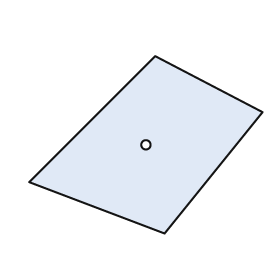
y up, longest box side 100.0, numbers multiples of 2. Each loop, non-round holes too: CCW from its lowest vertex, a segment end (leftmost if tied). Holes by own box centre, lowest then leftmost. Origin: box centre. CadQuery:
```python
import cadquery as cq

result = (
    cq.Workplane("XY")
    .moveTo(8.0, -38.0)
    .lineTo(50.0, 14.0)
    .lineTo(4.0, 38.0)
    .lineTo(-50.0, -16.0)
    .close()
    .moveTo(0.0, 0.0)
    .circle(2.0)
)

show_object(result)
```